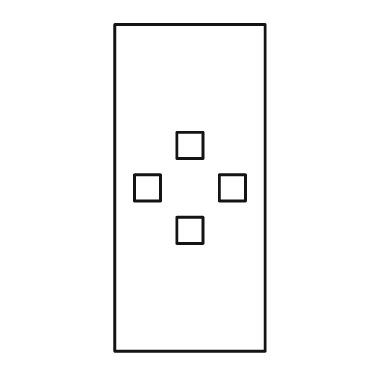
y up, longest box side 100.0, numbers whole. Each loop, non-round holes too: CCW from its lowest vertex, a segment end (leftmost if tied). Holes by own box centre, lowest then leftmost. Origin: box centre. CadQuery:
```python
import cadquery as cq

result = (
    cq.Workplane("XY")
    .moveTo(-23.0, -50.0)
    .lineTo(23.0, -50.0)
    .lineTo(23.0, 50.0)
    .lineTo(-23.0, 50.0)
    .close()
    .moveTo(-4.0, -17.0)
    .lineTo(4.0, -17.0)
    .lineTo(4.0, -9.0)
    .lineTo(-4.0, -9.0)
    .close()
    .moveTo(-17.0, -4.0)
    .lineTo(-9.0, -4.0)
    .lineTo(-9.0, 4.0)
    .lineTo(-17.0, 4.0)
    .close()
    .moveTo(9.0, -4.0)
    .lineTo(17.0, -4.0)
    .lineTo(17.0, 4.0)
    .lineTo(9.0, 4.0)
    .close()
    .moveTo(-4.0, 9.0)
    .lineTo(4.0, 9.0)
    .lineTo(4.0, 17.0)
    .lineTo(-4.0, 17.0)
    .close()
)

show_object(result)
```